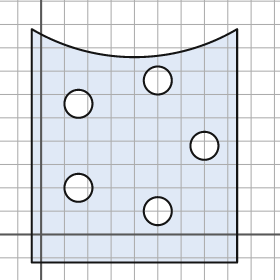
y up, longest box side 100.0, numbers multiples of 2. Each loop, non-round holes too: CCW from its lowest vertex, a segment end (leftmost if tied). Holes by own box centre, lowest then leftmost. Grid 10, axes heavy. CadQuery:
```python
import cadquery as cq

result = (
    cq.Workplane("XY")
    .moveTo(-4.0, -12.0)
    .lineTo(84.0, -12.0)
    .lineTo(84.0, 88.0)
    .threePointArc((40.0, 76.0), (-4.0, 88.0))
    .close()
    .moveTo(50.0, 10.0)
    .circle(6.0)
    .moveTo(16.0, 20.0)
    .circle(6.0)
    .moveTo(70.0, 38.0)
    .circle(6.0)
    .moveTo(16.0, 56.0)
    .circle(6.0)
    .moveTo(50.0, 66.0)
    .circle(6.0)
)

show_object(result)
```